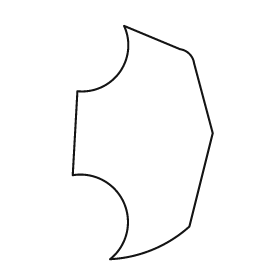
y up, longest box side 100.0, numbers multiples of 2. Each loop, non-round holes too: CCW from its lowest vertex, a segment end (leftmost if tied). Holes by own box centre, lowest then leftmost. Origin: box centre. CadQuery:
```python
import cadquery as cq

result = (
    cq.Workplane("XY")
    .moveTo(-14.0, -50.0)
    .threePointArc((4.0, -46.0), (20.0, -36.0))
    .lineTo(30.0, 4.0)
    .lineTo(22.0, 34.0)
    .threePointArc((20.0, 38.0), (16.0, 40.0))
    .lineTo(-8.0, 50.0)
    .threePointArc((-10.0, 30.0), (-28.0, 22.0))
    .lineTo(-30.0, -14.0)
    .threePointArc((-8.0, -26.0), (-14.0, -50.0))
    .close()
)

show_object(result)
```